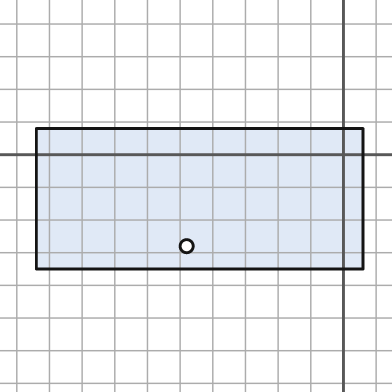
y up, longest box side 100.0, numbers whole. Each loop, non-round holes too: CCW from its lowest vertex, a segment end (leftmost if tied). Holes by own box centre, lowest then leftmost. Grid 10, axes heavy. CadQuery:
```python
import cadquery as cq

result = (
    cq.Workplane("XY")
    .moveTo(-94.0, -35.0)
    .lineTo(6.0, -35.0)
    .lineTo(6.0, 8.0)
    .lineTo(-94.0, 8.0)
    .close()
    .moveTo(-48.0, -28.0)
    .circle(2.0)
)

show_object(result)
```